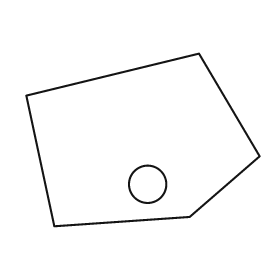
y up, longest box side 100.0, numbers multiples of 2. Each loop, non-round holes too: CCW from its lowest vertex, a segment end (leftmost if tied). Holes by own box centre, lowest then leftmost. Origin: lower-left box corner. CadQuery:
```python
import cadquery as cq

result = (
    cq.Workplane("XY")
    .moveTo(12.0, 0.0)
    .lineTo(70.0, 4.0)
    .lineTo(100.0, 30.0)
    .lineTo(74.0, 74.0)
    .lineTo(0.0, 56.0)
    .close()
    .moveTo(52.0, 18.0)
    .circle(8.0)
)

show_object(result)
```